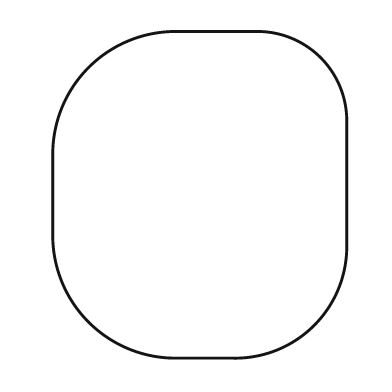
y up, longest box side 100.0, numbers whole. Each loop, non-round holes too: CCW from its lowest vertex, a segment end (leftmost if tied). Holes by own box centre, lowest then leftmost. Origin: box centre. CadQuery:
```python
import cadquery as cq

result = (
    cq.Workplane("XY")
    .moveTo(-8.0, -50.0)
    .lineTo(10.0, -50.0)
    .threePointArc((35.0, -40.0), (45.0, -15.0))
    .lineTo(45.0, 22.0)
    .threePointArc((37.0, 42.0), (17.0, 50.0))
    .lineTo(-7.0, 50.0)
    .threePointArc((-34.0, 39.0), (-45.0, 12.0))
    .lineTo(-45.0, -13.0)
    .threePointArc((-34.0, -39.0), (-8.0, -50.0))
    .close()
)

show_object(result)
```